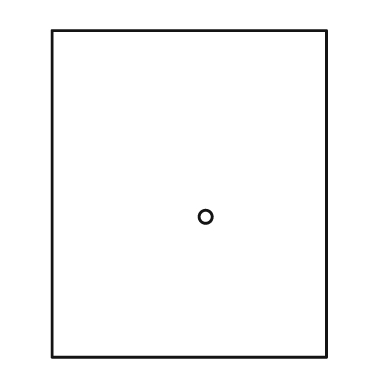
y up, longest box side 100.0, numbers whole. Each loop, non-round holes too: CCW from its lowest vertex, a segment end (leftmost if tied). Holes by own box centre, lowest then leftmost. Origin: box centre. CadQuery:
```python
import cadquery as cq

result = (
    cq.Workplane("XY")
    .moveTo(-42.0, -50.0)
    .lineTo(42.0, -50.0)
    .lineTo(42.0, 50.0)
    .lineTo(-42.0, 50.0)
    .close()
    .moveTo(5.0, -7.0)
    .circle(2.0)
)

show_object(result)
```